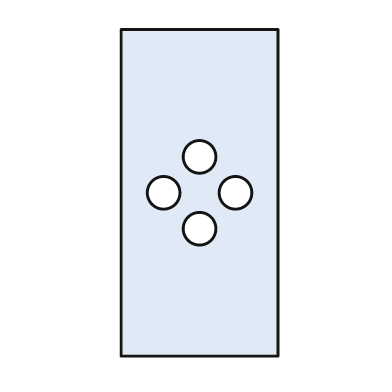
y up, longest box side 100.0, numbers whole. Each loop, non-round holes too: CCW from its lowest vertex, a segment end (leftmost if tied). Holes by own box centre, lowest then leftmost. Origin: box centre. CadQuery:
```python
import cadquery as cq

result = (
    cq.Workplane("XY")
    .moveTo(-24.0, -50.0)
    .lineTo(24.0, -50.0)
    .lineTo(24.0, 50.0)
    .lineTo(-24.0, 50.0)
    .close()
    .moveTo(0.0, -11.0)
    .circle(5.0)
    .moveTo(-11.0, 0.0)
    .circle(5.0)
    .moveTo(11.0, 0.0)
    .circle(5.0)
    .moveTo(0.0, 11.0)
    .circle(5.0)
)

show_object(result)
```